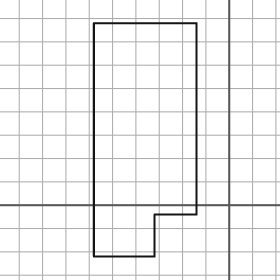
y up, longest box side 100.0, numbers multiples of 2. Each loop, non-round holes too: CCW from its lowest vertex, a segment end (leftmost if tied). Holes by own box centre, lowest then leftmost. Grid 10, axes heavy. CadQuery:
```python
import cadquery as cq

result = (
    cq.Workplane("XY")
    .moveTo(-58.0, -22.0)
    .lineTo(-32.0, -22.0)
    .lineTo(-32.0, -4.0)
    .lineTo(-14.0, -4.0)
    .lineTo(-14.0, 78.0)
    .lineTo(-58.0, 78.0)
    .close()
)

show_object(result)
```